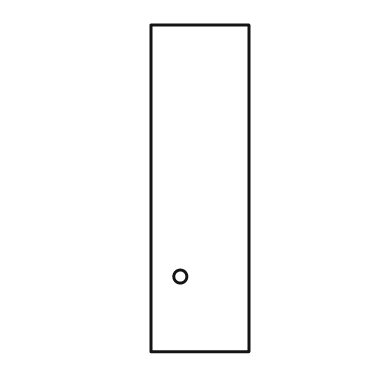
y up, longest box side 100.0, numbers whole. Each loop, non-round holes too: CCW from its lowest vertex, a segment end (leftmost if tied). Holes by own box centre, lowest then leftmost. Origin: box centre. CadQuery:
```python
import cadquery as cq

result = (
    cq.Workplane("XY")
    .moveTo(-15.0, -50.0)
    .lineTo(15.0, -50.0)
    .lineTo(15.0, 50.0)
    .lineTo(-15.0, 50.0)
    .close()
    .moveTo(-6.0, -27.0)
    .circle(2.0)
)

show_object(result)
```